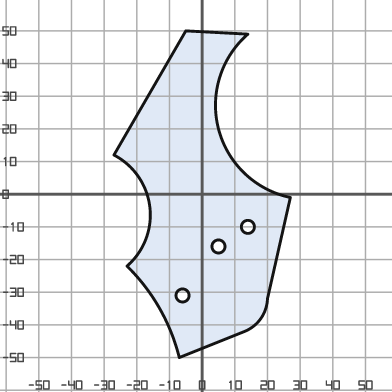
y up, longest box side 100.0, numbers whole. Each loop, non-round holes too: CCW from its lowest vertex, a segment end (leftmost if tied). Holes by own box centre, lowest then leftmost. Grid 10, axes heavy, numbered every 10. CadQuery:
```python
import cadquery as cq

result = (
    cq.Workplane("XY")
    .moveTo(-7.0, -50.0)
    .lineTo(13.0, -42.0)
    .threePointArc((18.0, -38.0), (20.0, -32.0))
    .lineTo(27.0, -1.0)
    .threePointArc((5.0, 20.0), (14.0, 49.0))
    .lineTo(-5.0, 50.0)
    .lineTo(-27.0, 12.0)
    .threePointArc((-16.0, -4.0), (-23.0, -22.0))
    .threePointArc((-13.0, -35.0), (-7.0, -50.0))
    .close()
    .moveTo(-6.0, -31.0)
    .circle(2.0)
    .moveTo(5.0, -16.0)
    .circle(2.0)
    .moveTo(14.0, -10.0)
    .circle(2.0)
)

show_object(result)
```